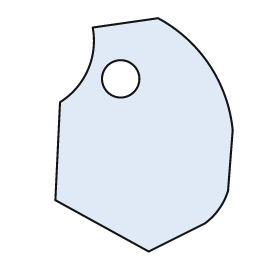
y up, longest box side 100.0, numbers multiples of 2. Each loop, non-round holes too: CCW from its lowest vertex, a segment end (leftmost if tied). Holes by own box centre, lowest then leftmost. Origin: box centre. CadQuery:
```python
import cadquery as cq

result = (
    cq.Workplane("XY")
    .moveTo(2.0, -50.0)
    .lineTo(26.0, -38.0)
    .threePointArc((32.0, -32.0), (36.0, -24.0))
    .lineTo(38.0, 2.0)
    .threePointArc((28.0, 30.0), (6.0, 50.0))
    .lineTo(-22.0, 46.0)
    .threePointArc((-24.0, 28.0), (-36.0, 14.0))
    .lineTo(-38.0, -28.0)
    .close()
    .moveTo(-10.0, 24.0)
    .circle(8.0)
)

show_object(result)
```